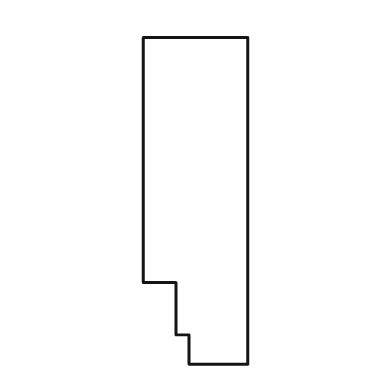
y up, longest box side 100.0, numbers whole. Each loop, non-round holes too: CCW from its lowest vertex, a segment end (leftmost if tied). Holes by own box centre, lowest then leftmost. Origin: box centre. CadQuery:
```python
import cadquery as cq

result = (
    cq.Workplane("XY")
    .moveTo(-2.0, -50.0)
    .lineTo(16.0, -50.0)
    .lineTo(16.0, 50.0)
    .lineTo(-16.0, 50.0)
    .lineTo(-16.0, -25.0)
    .lineTo(-6.0, -25.0)
    .lineTo(-6.0, -41.0)
    .lineTo(-2.0, -41.0)
    .close()
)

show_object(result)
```